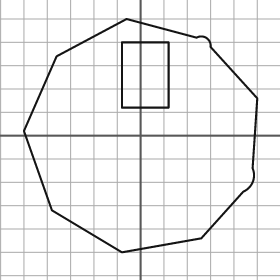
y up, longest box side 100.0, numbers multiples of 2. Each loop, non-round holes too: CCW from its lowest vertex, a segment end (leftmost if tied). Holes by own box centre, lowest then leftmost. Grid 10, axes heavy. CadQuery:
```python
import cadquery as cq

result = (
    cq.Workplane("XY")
    .moveTo(-8.0, -50.0)
    .lineTo(26.0, -44.0)
    .lineTo(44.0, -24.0)
    .threePointArc((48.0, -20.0), (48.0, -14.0))
    .lineTo(50.0, 16.0)
    .lineTo(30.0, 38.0)
    .threePointArc((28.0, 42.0), (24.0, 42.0))
    .lineTo(-6.0, 50.0)
    .lineTo(-36.0, 34.0)
    .lineTo(-50.0, 2.0)
    .lineTo(-38.0, -32.0)
    .close()
    .moveTo(-8.0, 12.0)
    .lineTo(12.0, 12.0)
    .lineTo(12.0, 40.0)
    .lineTo(-8.0, 40.0)
    .close()
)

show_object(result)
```